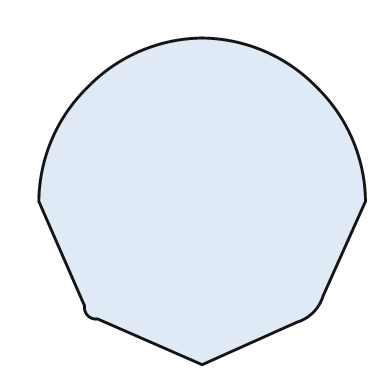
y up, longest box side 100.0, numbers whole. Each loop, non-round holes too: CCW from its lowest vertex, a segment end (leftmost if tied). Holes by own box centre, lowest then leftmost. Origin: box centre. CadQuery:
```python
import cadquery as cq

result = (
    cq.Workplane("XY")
    .moveTo(0.0, -50.0)
    .lineTo(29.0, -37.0)
    .threePointArc((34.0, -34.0), (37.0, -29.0))
    .lineTo(50.0, 0.0)
    .threePointArc((46.0, 19.0), (35.0, 35.0))
    .threePointArc((19.0, 46.0), (0.0, 50.0))
    .threePointArc((-19.0, 46.0), (-35.0, 35.0))
    .threePointArc((-46.0, 19.0), (-50.0, 0.0))
    .lineTo(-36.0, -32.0)
    .threePointArc((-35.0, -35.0), (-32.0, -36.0))
    .close()
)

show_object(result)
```